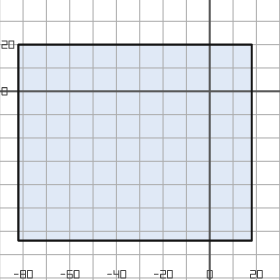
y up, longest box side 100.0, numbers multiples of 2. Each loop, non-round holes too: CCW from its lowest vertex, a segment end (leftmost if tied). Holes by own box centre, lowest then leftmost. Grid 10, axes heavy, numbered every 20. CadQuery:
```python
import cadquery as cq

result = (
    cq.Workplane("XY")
    .moveTo(-82.0, -64.0)
    .lineTo(18.0, -64.0)
    .lineTo(18.0, 20.0)
    .lineTo(-82.0, 20.0)
    .close()
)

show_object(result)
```